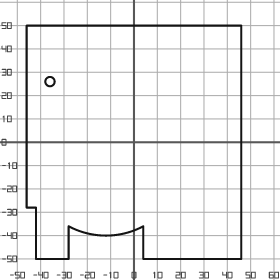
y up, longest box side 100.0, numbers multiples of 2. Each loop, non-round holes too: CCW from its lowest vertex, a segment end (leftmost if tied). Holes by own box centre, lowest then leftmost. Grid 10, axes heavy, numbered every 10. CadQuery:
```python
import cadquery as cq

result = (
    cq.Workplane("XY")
    .moveTo(-42.0, -50.0)
    .lineTo(-28.0, -50.0)
    .lineTo(-28.0, -36.0)
    .threePointArc((-12.0, -40.0), (4.0, -36.0))
    .lineTo(4.0, -50.0)
    .lineTo(46.0, -50.0)
    .lineTo(46.0, 50.0)
    .lineTo(-46.0, 50.0)
    .lineTo(-46.0, -28.0)
    .lineTo(-42.0, -28.0)
    .close()
    .moveTo(-36.0, 26.0)
    .circle(2.0)
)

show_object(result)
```